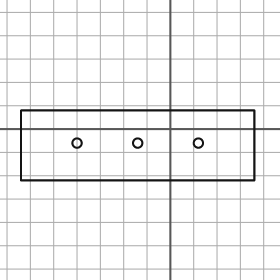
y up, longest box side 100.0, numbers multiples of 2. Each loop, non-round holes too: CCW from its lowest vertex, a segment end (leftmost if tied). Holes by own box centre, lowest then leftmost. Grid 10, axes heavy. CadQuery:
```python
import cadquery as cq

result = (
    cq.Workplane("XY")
    .moveTo(-64.0, -22.0)
    .lineTo(36.0, -22.0)
    .lineTo(36.0, 8.0)
    .lineTo(-64.0, 8.0)
    .close()
    .moveTo(-40.0, -6.0)
    .circle(2.0)
    .moveTo(-14.0, -6.0)
    .circle(2.0)
    .moveTo(12.0, -6.0)
    .circle(2.0)
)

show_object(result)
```